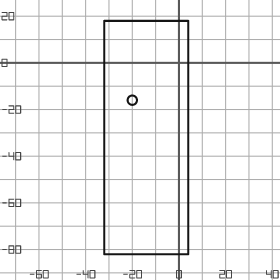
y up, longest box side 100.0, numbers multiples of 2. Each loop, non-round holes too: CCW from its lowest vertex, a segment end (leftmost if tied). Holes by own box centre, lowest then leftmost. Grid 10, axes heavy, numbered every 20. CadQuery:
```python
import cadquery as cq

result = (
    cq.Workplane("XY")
    .moveTo(-32.0, -82.0)
    .lineTo(4.0, -82.0)
    .lineTo(4.0, 18.0)
    .lineTo(-32.0, 18.0)
    .close()
    .moveTo(-20.0, -16.0)
    .circle(2.0)
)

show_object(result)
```